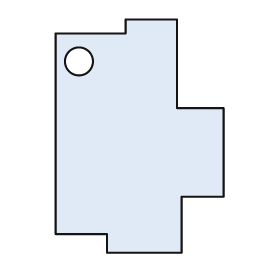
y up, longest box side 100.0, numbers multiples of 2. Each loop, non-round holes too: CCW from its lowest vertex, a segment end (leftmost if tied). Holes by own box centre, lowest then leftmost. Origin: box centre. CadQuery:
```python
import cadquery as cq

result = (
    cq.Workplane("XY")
    .moveTo(-14.0, -50.0)
    .lineTo(18.0, -50.0)
    .lineTo(18.0, -26.0)
    .lineTo(36.0, -26.0)
    .lineTo(36.0, 12.0)
    .lineTo(16.0, 12.0)
    .lineTo(16.0, 50.0)
    .lineTo(-6.0, 50.0)
    .lineTo(-6.0, 44.0)
    .lineTo(-36.0, 44.0)
    .lineTo(-36.0, -42.0)
    .lineTo(-14.0, -42.0)
    .close()
    .moveTo(-26.0, 32.0)
    .circle(6.0)
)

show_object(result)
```